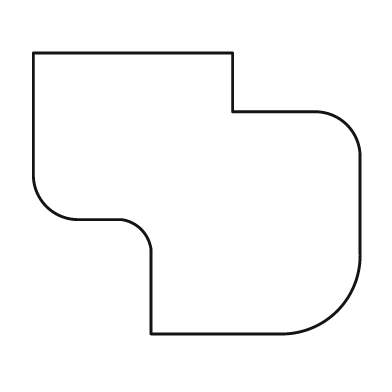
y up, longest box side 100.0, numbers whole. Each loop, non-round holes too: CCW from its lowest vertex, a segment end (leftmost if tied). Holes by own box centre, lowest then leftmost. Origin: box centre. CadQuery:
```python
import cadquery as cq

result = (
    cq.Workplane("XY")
    .moveTo(-14.0, -43.0)
    .lineTo(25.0, -43.0)
    .threePointArc((43.0, -36.0), (50.0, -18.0))
    .lineTo(50.0, 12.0)
    .threePointArc((46.0, 21.0), (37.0, 25.0))
    .lineTo(11.0, 25.0)
    .lineTo(11.0, 43.0)
    .lineTo(-50.0, 43.0)
    .lineTo(-50.0, 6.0)
    .threePointArc((-46.0, -4.0), (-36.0, -8.0))
    .lineTo(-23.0, -8.0)
    .threePointArc((-17.0, -11.0), (-14.0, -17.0))
    .close()
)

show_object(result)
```